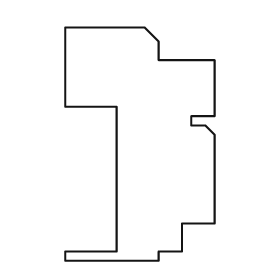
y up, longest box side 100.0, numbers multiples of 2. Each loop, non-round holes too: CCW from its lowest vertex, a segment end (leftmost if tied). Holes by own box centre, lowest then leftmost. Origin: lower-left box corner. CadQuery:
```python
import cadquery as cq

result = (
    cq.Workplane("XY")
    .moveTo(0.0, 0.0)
    .lineTo(40.0, 0.0)
    .lineTo(40.0, 4.0)
    .lineTo(50.0, 4.0)
    .lineTo(50.0, 16.0)
    .lineTo(64.0, 16.0)
    .lineTo(64.0, 54.0)
    .lineTo(60.0, 58.0)
    .lineTo(54.0, 58.0)
    .lineTo(54.0, 62.0)
    .lineTo(64.0, 62.0)
    .lineTo(64.0, 86.0)
    .lineTo(40.0, 86.0)
    .lineTo(40.0, 94.0)
    .lineTo(34.0, 100.0)
    .lineTo(0.0, 100.0)
    .lineTo(0.0, 66.0)
    .lineTo(22.0, 66.0)
    .lineTo(22.0, 4.0)
    .lineTo(0.0, 4.0)
    .close()
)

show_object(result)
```